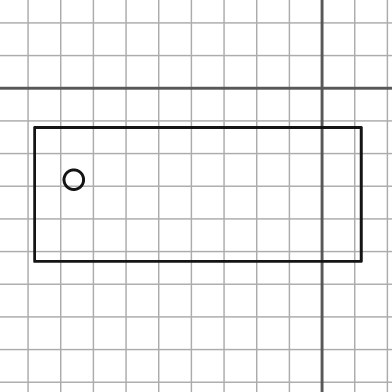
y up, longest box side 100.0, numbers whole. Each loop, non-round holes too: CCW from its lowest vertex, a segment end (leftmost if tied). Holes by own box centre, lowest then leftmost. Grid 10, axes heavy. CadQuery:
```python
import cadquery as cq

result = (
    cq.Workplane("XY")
    .moveTo(-88.0, -53.0)
    .lineTo(12.0, -53.0)
    .lineTo(12.0, -12.0)
    .lineTo(-88.0, -12.0)
    .close()
    .moveTo(-76.0, -28.0)
    .circle(3.0)
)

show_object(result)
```